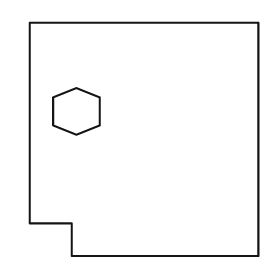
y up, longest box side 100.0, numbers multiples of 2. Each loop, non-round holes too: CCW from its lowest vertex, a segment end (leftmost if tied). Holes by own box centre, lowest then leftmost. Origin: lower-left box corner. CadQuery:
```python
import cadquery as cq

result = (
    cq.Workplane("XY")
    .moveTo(18.0, 0.0)
    .lineTo(98.0, 0.0)
    .lineTo(98.0, 100.0)
    .lineTo(0.0, 100.0)
    .lineTo(0.0, 14.0)
    .lineTo(18.0, 14.0)
    .close()
    .moveTo(20.0, 52.0)
    .lineTo(30.0, 56.0)
    .lineTo(30.0, 68.0)
    .lineTo(20.0, 72.0)
    .lineTo(10.0, 68.0)
    .lineTo(10.0, 56.0)
    .close()
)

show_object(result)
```